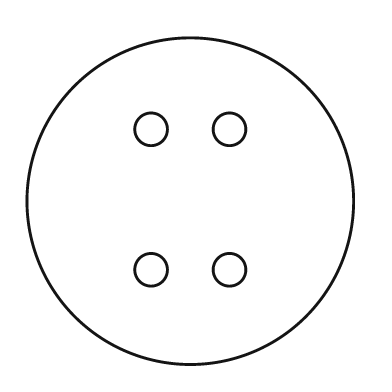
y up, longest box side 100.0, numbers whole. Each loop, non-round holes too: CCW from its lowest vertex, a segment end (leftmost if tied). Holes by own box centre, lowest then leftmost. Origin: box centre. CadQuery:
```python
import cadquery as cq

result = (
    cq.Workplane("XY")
    .moveTo(0.0, 0.0)
    .circle(50.0)
    .moveTo(-12.0, -21.0)
    .circle(5.0)
    .moveTo(12.0, -21.0)
    .circle(5.0)
    .moveTo(-12.0, 22.0)
    .circle(5.0)
    .moveTo(12.0, 22.0)
    .circle(5.0)
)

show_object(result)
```